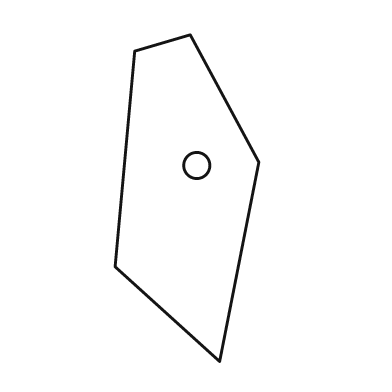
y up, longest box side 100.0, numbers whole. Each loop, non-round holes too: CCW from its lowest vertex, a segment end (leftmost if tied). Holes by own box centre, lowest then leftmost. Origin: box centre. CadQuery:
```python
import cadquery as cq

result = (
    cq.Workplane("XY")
    .moveTo(10.0, -50.0)
    .lineTo(22.0, 11.0)
    .lineTo(1.0, 50.0)
    .lineTo(-16.0, 45.0)
    .lineTo(-22.0, -21.0)
    .close()
    .moveTo(3.0, 10.0)
    .circle(4.0)
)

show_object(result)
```